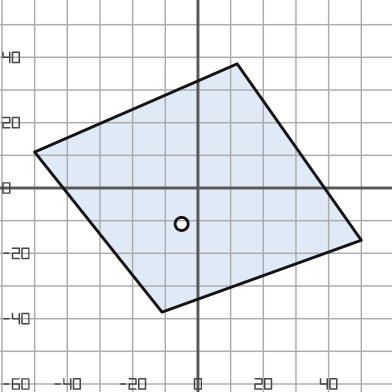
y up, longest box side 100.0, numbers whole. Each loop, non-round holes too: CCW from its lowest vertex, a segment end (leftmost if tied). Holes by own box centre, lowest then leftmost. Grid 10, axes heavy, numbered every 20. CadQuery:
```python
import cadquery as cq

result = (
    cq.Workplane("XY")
    .moveTo(-11.0, -38.0)
    .lineTo(50.0, -16.0)
    .lineTo(12.0, 38.0)
    .lineTo(-50.0, 11.0)
    .close()
    .moveTo(-5.0, -11.0)
    .circle(2.0)
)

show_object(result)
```